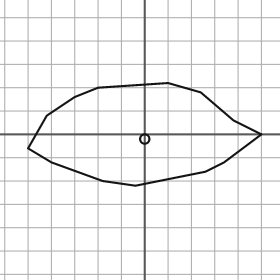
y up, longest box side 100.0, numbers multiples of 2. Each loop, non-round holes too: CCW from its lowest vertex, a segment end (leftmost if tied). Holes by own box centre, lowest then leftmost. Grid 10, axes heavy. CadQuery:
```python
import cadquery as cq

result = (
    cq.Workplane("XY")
    .moveTo(-4.0, -22.0)
    .lineTo(26.0, -16.0)
    .lineTo(34.0, -12.0)
    .lineTo(50.0, 0.0)
    .lineTo(38.0, 6.0)
    .lineTo(24.0, 18.0)
    .lineTo(10.0, 22.0)
    .lineTo(-20.0, 20.0)
    .lineTo(-30.0, 16.0)
    .lineTo(-42.0, 8.0)
    .lineTo(-50.0, -6.0)
    .lineTo(-40.0, -12.0)
    .lineTo(-18.0, -20.0)
    .close()
    .moveTo(0.0, -2.0)
    .circle(2.0)
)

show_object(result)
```